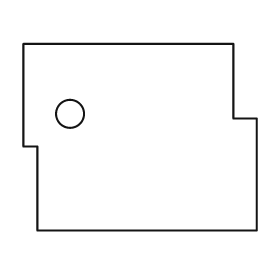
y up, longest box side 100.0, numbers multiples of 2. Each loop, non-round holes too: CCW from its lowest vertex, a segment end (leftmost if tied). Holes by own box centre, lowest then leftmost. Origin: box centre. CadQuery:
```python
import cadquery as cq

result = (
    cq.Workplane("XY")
    .moveTo(-44.0, -40.0)
    .lineTo(50.0, -40.0)
    .lineTo(50.0, 8.0)
    .lineTo(40.0, 8.0)
    .lineTo(40.0, 40.0)
    .lineTo(-50.0, 40.0)
    .lineTo(-50.0, -4.0)
    .lineTo(-44.0, -4.0)
    .close()
    .moveTo(-30.0, 10.0)
    .circle(6.0)
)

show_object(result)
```